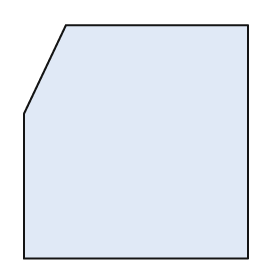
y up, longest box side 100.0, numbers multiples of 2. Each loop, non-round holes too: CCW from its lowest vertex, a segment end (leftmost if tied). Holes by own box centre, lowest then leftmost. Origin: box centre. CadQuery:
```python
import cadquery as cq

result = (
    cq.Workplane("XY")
    .moveTo(-48.0, -50.0)
    .lineTo(48.0, -50.0)
    .lineTo(48.0, 50.0)
    .lineTo(-30.0, 50.0)
    .lineTo(-48.0, 12.0)
    .close()
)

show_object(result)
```